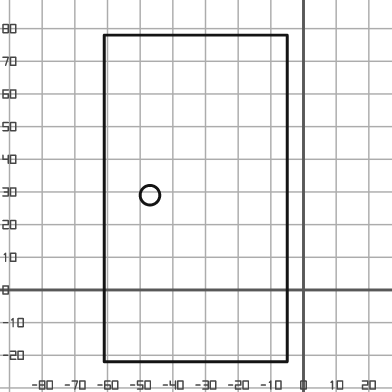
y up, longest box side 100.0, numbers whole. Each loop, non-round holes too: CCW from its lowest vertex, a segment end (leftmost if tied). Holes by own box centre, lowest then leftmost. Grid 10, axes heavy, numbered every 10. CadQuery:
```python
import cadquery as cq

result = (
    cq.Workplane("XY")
    .moveTo(-61.0, -22.0)
    .lineTo(-5.0, -22.0)
    .lineTo(-5.0, 78.0)
    .lineTo(-61.0, 78.0)
    .close()
    .moveTo(-47.0, 29.0)
    .circle(3.0)
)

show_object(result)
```